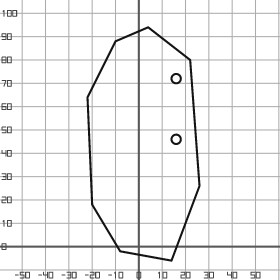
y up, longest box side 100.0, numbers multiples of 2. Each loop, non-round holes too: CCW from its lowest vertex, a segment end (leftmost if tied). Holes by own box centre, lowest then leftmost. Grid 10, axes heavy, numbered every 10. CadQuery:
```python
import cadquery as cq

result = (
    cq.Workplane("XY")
    .moveTo(14.0, -6.0)
    .lineTo(26.0, 26.0)
    .lineTo(22.0, 80.0)
    .lineTo(4.0, 94.0)
    .lineTo(-10.0, 88.0)
    .lineTo(-22.0, 64.0)
    .lineTo(-20.0, 18.0)
    .lineTo(-8.0, -2.0)
    .close()
    .moveTo(16.0, 46.0)
    .circle(2.0)
    .moveTo(16.0, 72.0)
    .circle(2.0)
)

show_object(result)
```